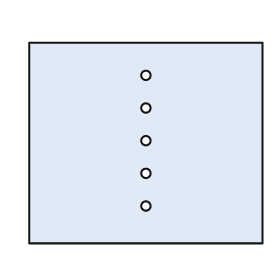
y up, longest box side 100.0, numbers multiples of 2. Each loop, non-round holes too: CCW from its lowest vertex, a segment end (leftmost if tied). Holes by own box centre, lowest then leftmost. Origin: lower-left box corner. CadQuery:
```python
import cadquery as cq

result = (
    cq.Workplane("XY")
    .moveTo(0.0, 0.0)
    .lineTo(100.0, 0.0)
    .lineTo(100.0, 86.0)
    .lineTo(0.0, 86.0)
    .close()
    .moveTo(50.0, 16.0)
    .circle(2.0)
    .moveTo(50.0, 30.0)
    .circle(2.0)
    .moveTo(50.0, 44.0)
    .circle(2.0)
    .moveTo(50.0, 58.0)
    .circle(2.0)
    .moveTo(50.0, 72.0)
    .circle(2.0)
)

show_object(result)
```